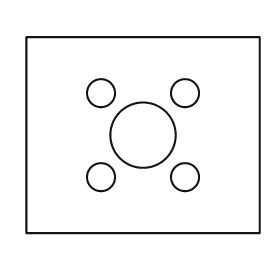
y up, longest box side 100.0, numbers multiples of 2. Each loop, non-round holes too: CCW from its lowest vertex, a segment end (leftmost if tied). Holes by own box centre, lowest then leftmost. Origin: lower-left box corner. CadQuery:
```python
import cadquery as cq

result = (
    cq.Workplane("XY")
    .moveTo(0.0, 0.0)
    .lineTo(100.0, 0.0)
    .lineTo(100.0, 84.0)
    .lineTo(0.0, 84.0)
    .close()
    .moveTo(32.0, 24.0)
    .circle(6.0)
    .moveTo(68.0, 24.0)
    .circle(6.0)
    .moveTo(50.0, 42.0)
    .circle(14.0)
    .moveTo(32.0, 60.0)
    .circle(6.0)
    .moveTo(68.0, 60.0)
    .circle(6.0)
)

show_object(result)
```